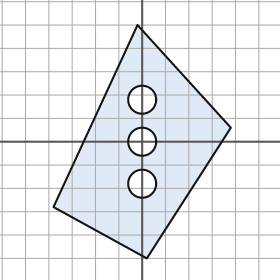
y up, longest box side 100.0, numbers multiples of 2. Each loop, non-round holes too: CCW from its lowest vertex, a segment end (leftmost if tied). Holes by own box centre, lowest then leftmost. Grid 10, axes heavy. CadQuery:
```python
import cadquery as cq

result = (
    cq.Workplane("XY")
    .moveTo(2.0, -50.0)
    .lineTo(38.0, 6.0)
    .lineTo(-2.0, 50.0)
    .lineTo(-38.0, -28.0)
    .close()
    .moveTo(0.0, -18.0)
    .circle(6.0)
    .moveTo(0.0, 0.0)
    .circle(6.0)
    .moveTo(0.0, 18.0)
    .circle(6.0)
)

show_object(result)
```